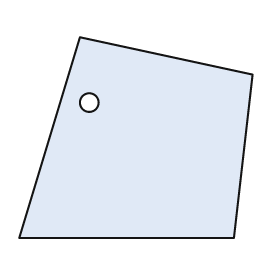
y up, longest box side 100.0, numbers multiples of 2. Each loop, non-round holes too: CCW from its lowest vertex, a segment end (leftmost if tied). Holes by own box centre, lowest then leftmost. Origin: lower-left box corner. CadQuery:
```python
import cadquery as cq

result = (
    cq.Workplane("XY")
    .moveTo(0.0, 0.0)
    .lineTo(92.0, 0.0)
    .lineTo(100.0, 70.0)
    .lineTo(26.0, 86.0)
    .close()
    .moveTo(30.0, 58.0)
    .circle(4.0)
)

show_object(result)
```